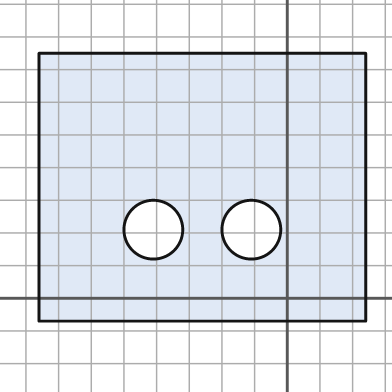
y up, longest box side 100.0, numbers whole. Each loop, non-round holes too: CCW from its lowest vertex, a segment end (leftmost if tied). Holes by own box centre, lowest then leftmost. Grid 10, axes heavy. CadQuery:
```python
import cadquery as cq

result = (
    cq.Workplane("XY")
    .moveTo(-76.0, -7.0)
    .lineTo(24.0, -7.0)
    .lineTo(24.0, 75.0)
    .lineTo(-76.0, 75.0)
    .close()
    .moveTo(-41.0, 21.0)
    .circle(9.0)
    .moveTo(-11.0, 21.0)
    .circle(9.0)
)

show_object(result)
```